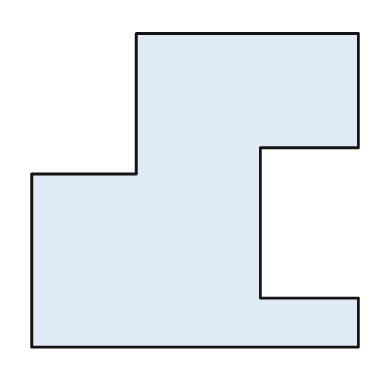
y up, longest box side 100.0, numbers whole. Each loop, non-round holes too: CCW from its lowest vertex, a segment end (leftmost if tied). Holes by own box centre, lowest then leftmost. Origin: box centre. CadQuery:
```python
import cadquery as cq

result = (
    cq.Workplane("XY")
    .moveTo(-50.0, -48.0)
    .lineTo(50.0, -48.0)
    .lineTo(50.0, -33.0)
    .lineTo(20.0, -33.0)
    .lineTo(20.0, 13.0)
    .lineTo(50.0, 13.0)
    .lineTo(50.0, 48.0)
    .lineTo(-18.0, 48.0)
    .lineTo(-18.0, 5.0)
    .lineTo(-50.0, 5.0)
    .close()
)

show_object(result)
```